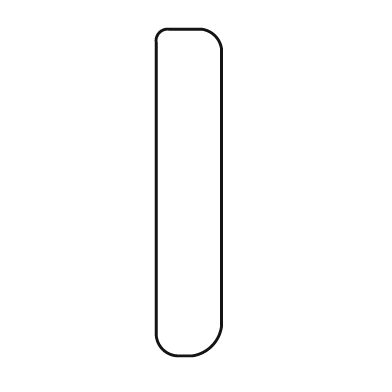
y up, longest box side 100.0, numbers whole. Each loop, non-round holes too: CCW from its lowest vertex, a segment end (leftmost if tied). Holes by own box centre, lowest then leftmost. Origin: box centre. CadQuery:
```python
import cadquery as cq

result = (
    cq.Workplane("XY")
    .moveTo(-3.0, -50.0)
    .lineTo(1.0, -50.0)
    .threePointArc((7.0, -47.0), (10.0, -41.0))
    .lineTo(10.0, 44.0)
    .threePointArc((8.0, 48.0), (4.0, 50.0))
    .lineTo(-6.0, 50.0)
    .threePointArc((-9.0, 49.0), (-10.0, 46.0))
    .lineTo(-10.0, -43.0)
    .threePointArc((-8.0, -48.0), (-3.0, -50.0))
    .close()
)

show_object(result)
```